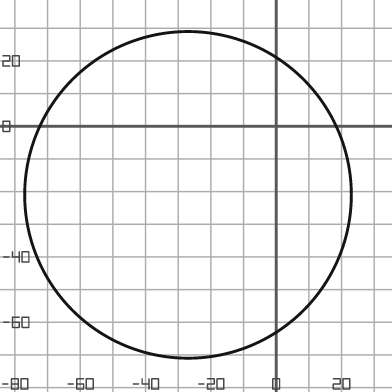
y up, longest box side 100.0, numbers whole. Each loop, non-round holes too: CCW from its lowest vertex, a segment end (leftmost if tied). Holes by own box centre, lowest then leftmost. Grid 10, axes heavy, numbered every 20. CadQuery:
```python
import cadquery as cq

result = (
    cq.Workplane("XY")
    .moveTo(-27.0, -21.0)
    .circle(50.0)
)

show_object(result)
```